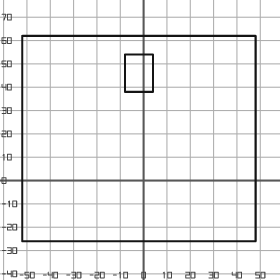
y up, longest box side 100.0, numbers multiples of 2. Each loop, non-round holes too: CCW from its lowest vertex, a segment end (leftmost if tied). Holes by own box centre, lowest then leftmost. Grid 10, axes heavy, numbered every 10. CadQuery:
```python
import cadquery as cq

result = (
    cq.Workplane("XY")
    .moveTo(-52.0, -26.0)
    .lineTo(48.0, -26.0)
    .lineTo(48.0, 62.0)
    .lineTo(-52.0, 62.0)
    .close()
    .moveTo(-8.0, 38.0)
    .lineTo(4.0, 38.0)
    .lineTo(4.0, 54.0)
    .lineTo(-8.0, 54.0)
    .close()
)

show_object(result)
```